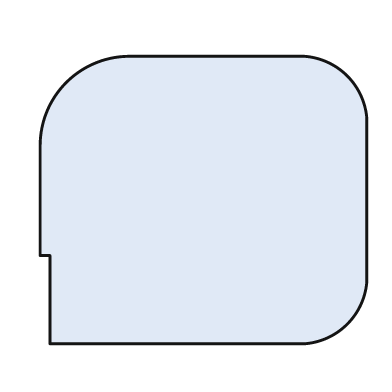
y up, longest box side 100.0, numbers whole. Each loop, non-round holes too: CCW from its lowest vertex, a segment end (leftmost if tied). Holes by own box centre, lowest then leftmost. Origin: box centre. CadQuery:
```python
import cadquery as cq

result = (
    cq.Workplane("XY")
    .moveTo(-47.0, -44.0)
    .lineTo(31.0, -44.0)
    .threePointArc((44.0, -38.0), (50.0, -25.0))
    .lineTo(50.0, 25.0)
    .threePointArc((44.0, 38.0), (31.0, 44.0))
    .lineTo(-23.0, 44.0)
    .threePointArc((-42.0, 36.0), (-50.0, 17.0))
    .lineTo(-50.0, -17.0)
    .lineTo(-47.0, -17.0)
    .close()
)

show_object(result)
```